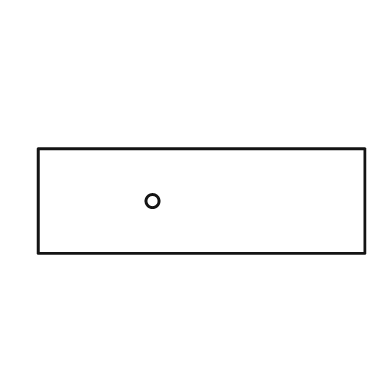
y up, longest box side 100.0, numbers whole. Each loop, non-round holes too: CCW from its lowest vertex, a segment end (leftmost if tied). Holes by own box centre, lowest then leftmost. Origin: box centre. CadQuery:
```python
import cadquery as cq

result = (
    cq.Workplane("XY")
    .moveTo(-50.0, -16.0)
    .lineTo(50.0, -16.0)
    .lineTo(50.0, 16.0)
    .lineTo(-50.0, 16.0)
    .close()
    .moveTo(-15.0, 0.0)
    .circle(2.0)
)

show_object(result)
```